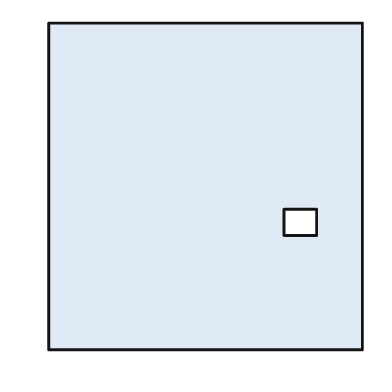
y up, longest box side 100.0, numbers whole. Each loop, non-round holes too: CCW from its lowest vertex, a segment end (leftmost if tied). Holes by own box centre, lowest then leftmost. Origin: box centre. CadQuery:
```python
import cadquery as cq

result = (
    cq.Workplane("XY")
    .moveTo(-48.0, -50.0)
    .lineTo(48.0, -50.0)
    .lineTo(48.0, 50.0)
    .lineTo(-48.0, 50.0)
    .close()
    .moveTo(24.0, -15.0)
    .lineTo(34.0, -15.0)
    .lineTo(34.0, -7.0)
    .lineTo(24.0, -7.0)
    .close()
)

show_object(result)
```